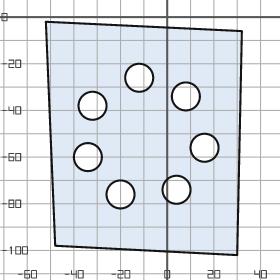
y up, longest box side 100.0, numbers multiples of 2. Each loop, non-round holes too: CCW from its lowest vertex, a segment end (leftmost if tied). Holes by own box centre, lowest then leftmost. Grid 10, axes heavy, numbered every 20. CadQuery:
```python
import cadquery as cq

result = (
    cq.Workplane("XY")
    .moveTo(30.0, -102.0)
    .lineTo(32.0, -6.0)
    .lineTo(-52.0, -2.0)
    .lineTo(-48.0, -98.0)
    .close()
    .moveTo(-20.0, -76.0)
    .circle(6.0)
    .moveTo(4.0, -74.0)
    .circle(6.0)
    .moveTo(-34.0, -60.0)
    .circle(6.0)
    .moveTo(16.0, -56.0)
    .circle(6.0)
    .moveTo(-32.0, -38.0)
    .circle(6.0)
    .moveTo(8.0, -34.0)
    .circle(6.0)
    .moveTo(-12.0, -26.0)
    .circle(6.0)
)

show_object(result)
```